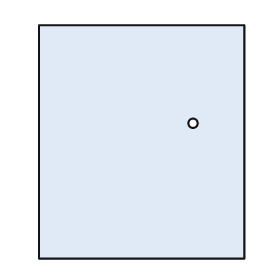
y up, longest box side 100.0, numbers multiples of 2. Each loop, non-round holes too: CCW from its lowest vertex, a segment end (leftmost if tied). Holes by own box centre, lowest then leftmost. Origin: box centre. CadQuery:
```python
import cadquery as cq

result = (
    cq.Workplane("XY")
    .moveTo(-44.0, -50.0)
    .lineTo(44.0, -50.0)
    .lineTo(44.0, 50.0)
    .lineTo(-44.0, 50.0)
    .close()
    .moveTo(22.0, 8.0)
    .circle(2.0)
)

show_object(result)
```